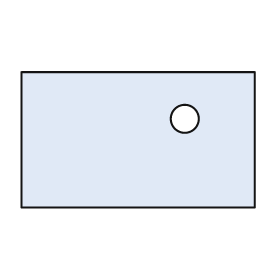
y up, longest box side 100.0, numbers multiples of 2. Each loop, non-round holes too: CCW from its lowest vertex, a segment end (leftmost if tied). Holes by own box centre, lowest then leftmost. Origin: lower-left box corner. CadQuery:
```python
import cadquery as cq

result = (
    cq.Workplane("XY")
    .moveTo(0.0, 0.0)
    .lineTo(100.0, 0.0)
    .lineTo(100.0, 58.0)
    .lineTo(0.0, 58.0)
    .close()
    .moveTo(70.0, 38.0)
    .circle(6.0)
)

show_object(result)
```